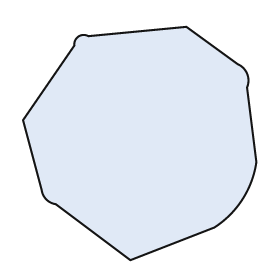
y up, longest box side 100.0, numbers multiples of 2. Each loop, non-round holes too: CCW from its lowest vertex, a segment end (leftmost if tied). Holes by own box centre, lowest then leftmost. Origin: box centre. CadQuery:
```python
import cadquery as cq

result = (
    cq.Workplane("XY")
    .moveTo(-4.0, -50.0)
    .lineTo(32.0, -36.0)
    .threePointArc((44.0, -24.0), (50.0, -8.0))
    .lineTo(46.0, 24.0)
    .threePointArc((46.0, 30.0), (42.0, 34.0))
    .lineTo(20.0, 50.0)
    .lineTo(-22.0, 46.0)
    .threePointArc((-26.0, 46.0), (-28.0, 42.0))
    .lineTo(-50.0, 10.0)
    .lineTo(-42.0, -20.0)
    .threePointArc((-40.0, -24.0), (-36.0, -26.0))
    .close()
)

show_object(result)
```